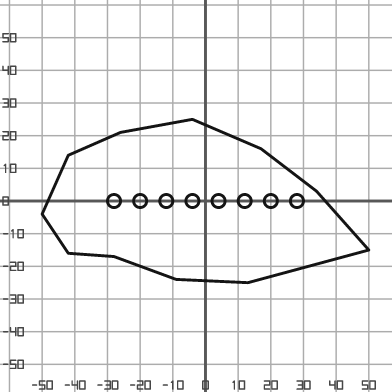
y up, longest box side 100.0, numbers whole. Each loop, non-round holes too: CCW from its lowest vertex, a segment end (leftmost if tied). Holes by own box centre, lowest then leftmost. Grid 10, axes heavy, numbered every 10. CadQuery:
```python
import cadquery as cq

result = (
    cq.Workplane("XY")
    .moveTo(13.0, -25.0)
    .lineTo(50.0, -15.0)
    .lineTo(34.0, 3.0)
    .lineTo(17.0, 16.0)
    .lineTo(-4.0, 25.0)
    .lineTo(-26.0, 21.0)
    .lineTo(-42.0, 14.0)
    .lineTo(-50.0, -4.0)
    .lineTo(-42.0, -16.0)
    .lineTo(-28.0, -17.0)
    .lineTo(-9.0, -24.0)
    .close()
    .moveTo(-28.0, 0.0)
    .circle(2.0)
    .moveTo(-20.0, 0.0)
    .circle(2.0)
    .moveTo(-12.0, 0.0)
    .circle(2.0)
    .moveTo(-4.0, 0.0)
    .circle(2.0)
    .moveTo(4.0, 0.0)
    .circle(2.0)
    .moveTo(12.0, 0.0)
    .circle(2.0)
    .moveTo(20.0, 0.0)
    .circle(2.0)
    .moveTo(28.0, 0.0)
    .circle(2.0)
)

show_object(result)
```